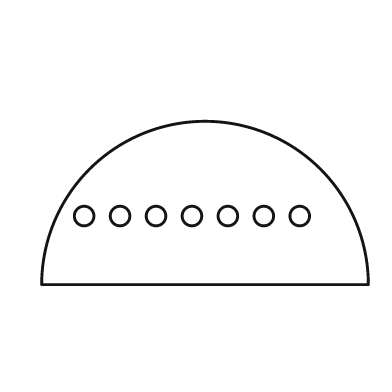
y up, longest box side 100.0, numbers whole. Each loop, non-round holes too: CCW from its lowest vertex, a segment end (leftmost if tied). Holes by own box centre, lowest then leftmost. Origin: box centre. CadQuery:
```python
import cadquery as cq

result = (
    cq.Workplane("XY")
    .moveTo(-50.0, -25.0)
    .lineTo(50.0, -25.0)
    .threePointArc((0.0, 25.0), (-50.0, -25.0))
    .close()
    .moveTo(-37.0, -4.0)
    .circle(3.0)
    .moveTo(-26.0, -4.0)
    .circle(3.0)
    .moveTo(-15.0, -4.0)
    .circle(3.0)
    .moveTo(-4.0, -4.0)
    .circle(3.0)
    .moveTo(7.0, -4.0)
    .circle(3.0)
    .moveTo(18.0, -4.0)
    .circle(3.0)
    .moveTo(29.0, -4.0)
    .circle(3.0)
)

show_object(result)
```